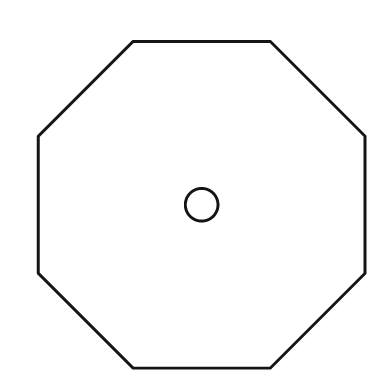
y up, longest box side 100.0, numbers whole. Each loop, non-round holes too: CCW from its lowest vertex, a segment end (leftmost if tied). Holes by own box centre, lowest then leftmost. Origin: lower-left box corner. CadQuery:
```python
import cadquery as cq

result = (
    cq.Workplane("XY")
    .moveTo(29.0, 0.0)
    .lineTo(71.0, 0.0)
    .lineTo(100.0, 29.0)
    .lineTo(100.0, 71.0)
    .lineTo(71.0, 100.0)
    .lineTo(29.0, 100.0)
    .lineTo(0.0, 71.0)
    .lineTo(0.0, 29.0)
    .close()
    .moveTo(50.0, 50.0)
    .circle(5.0)
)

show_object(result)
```